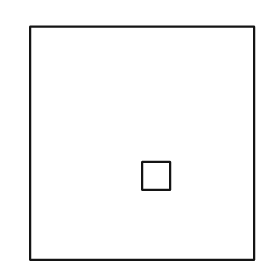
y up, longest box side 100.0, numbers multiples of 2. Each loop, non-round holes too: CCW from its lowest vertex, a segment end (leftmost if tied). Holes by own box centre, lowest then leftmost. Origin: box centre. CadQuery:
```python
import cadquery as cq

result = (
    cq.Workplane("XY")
    .moveTo(-48.0, -50.0)
    .lineTo(48.0, -50.0)
    .lineTo(48.0, 50.0)
    .lineTo(-48.0, 50.0)
    .close()
    .moveTo(0.0, -20.0)
    .lineTo(12.0, -20.0)
    .lineTo(12.0, -8.0)
    .lineTo(0.0, -8.0)
    .close()
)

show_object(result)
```